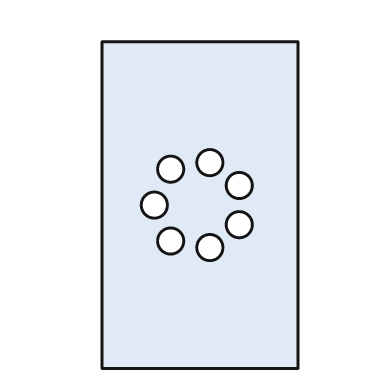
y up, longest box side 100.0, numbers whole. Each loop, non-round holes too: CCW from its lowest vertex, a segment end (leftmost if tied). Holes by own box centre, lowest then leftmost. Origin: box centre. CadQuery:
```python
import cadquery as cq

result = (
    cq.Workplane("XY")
    .moveTo(-30.0, -50.0)
    .lineTo(30.0, -50.0)
    .lineTo(30.0, 50.0)
    .lineTo(-30.0, 50.0)
    .close()
    .moveTo(3.0, -13.0)
    .circle(4.0)
    .moveTo(-9.0, -11.0)
    .circle(4.0)
    .moveTo(12.0, -6.0)
    .circle(4.0)
    .moveTo(-14.0, 0.0)
    .circle(4.0)
    .moveTo(12.0, 6.0)
    .circle(4.0)
    .moveTo(-9.0, 11.0)
    .circle(4.0)
    .moveTo(3.0, 13.0)
    .circle(4.0)
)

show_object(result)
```